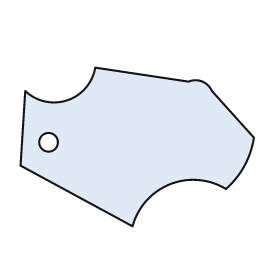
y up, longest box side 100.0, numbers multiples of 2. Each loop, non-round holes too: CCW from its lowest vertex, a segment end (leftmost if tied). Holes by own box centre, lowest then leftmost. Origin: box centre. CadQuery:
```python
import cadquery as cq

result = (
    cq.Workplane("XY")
    .moveTo(-2.0, -34.0)
    .threePointArc((14.0, -16.0), (38.0, -18.0))
    .threePointArc((46.0, -8.0), (50.0, 4.0))
    .lineTo(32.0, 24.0)
    .threePointArc((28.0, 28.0), (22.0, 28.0))
    .lineTo(-18.0, 34.0)
    .threePointArc((-30.0, 20.0), (-48.0, 24.0))
    .lineTo(-50.0, -8.0)
    .close()
    .moveTo(-38.0, 2.0)
    .circle(4.0)
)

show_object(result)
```